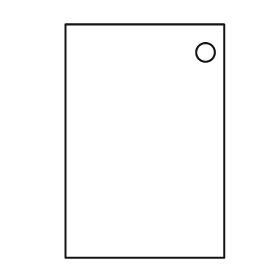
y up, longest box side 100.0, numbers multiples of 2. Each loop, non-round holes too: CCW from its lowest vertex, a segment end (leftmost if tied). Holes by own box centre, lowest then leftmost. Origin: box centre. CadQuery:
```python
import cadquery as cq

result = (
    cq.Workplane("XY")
    .moveTo(-34.0, -50.0)
    .lineTo(34.0, -50.0)
    .lineTo(34.0, 50.0)
    .lineTo(-34.0, 50.0)
    .close()
    .moveTo(26.0, 38.0)
    .circle(4.0)
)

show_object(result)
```